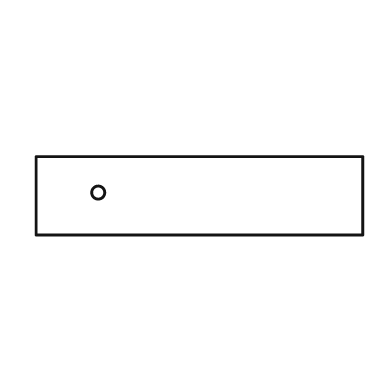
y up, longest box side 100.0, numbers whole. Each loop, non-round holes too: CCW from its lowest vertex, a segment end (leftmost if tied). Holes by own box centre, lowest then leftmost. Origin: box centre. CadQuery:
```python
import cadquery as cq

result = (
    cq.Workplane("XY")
    .moveTo(-50.0, -12.0)
    .lineTo(50.0, -12.0)
    .lineTo(50.0, 12.0)
    .lineTo(-50.0, 12.0)
    .close()
    .moveTo(-31.0, 1.0)
    .circle(2.0)
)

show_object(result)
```